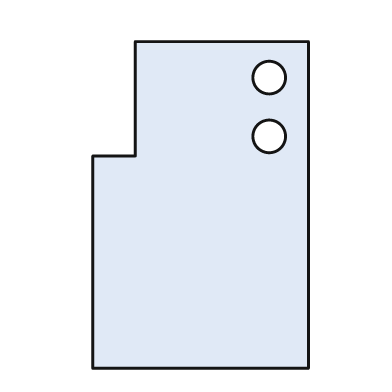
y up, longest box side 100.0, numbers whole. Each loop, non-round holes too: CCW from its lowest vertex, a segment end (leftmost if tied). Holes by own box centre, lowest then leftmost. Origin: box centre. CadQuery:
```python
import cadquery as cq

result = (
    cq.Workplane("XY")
    .moveTo(-33.0, -50.0)
    .lineTo(33.0, -50.0)
    .lineTo(33.0, 50.0)
    .lineTo(-20.0, 50.0)
    .lineTo(-20.0, 15.0)
    .lineTo(-33.0, 15.0)
    .close()
    .moveTo(21.0, 21.0)
    .circle(5.0)
    .moveTo(21.0, 39.0)
    .circle(5.0)
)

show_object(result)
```